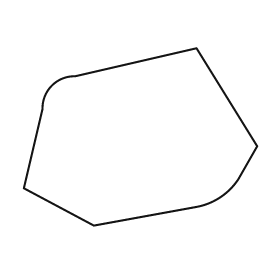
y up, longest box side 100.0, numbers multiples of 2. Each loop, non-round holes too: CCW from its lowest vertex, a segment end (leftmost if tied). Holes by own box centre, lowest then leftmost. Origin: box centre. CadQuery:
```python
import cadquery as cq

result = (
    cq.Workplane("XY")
    .moveTo(-20.0, -38.0)
    .lineTo(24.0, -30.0)
    .threePointArc((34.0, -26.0), (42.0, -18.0))
    .lineTo(50.0, -4.0)
    .lineTo(24.0, 38.0)
    .lineTo(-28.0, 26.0)
    .threePointArc((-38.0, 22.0), (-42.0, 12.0))
    .lineTo(-50.0, -22.0)
    .close()
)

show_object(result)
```